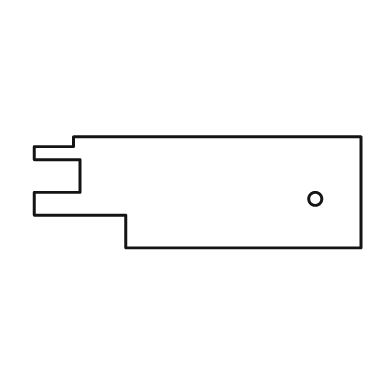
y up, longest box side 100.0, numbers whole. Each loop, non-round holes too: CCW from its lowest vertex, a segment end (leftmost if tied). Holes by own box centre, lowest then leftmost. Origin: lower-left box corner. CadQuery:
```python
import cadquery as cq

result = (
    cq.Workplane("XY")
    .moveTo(28.0, 0.0)
    .lineTo(100.0, 0.0)
    .lineTo(100.0, 34.0)
    .lineTo(12.0, 34.0)
    .lineTo(12.0, 31.0)
    .lineTo(0.0, 31.0)
    .lineTo(0.0, 27.0)
    .lineTo(14.0, 27.0)
    .lineTo(14.0, 17.0)
    .lineTo(0.0, 17.0)
    .lineTo(0.0, 10.0)
    .lineTo(28.0, 10.0)
    .close()
    .moveTo(86.0, 15.0)
    .circle(2.0)
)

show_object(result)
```